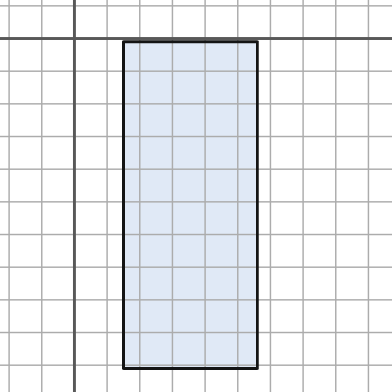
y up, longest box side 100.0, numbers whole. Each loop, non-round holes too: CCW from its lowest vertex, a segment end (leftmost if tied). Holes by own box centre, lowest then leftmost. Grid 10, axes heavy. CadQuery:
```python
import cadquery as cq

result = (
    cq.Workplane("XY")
    .moveTo(15.0, -101.0)
    .lineTo(56.0, -101.0)
    .lineTo(56.0, -1.0)
    .lineTo(15.0, -1.0)
    .close()
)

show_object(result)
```